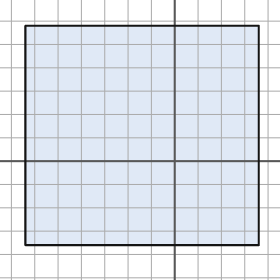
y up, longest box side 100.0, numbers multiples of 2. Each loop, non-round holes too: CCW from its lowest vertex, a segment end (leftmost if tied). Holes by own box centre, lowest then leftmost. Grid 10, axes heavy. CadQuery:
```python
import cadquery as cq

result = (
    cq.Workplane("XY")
    .moveTo(-64.0, -36.0)
    .lineTo(36.0, -36.0)
    .lineTo(36.0, 58.0)
    .lineTo(-64.0, 58.0)
    .close()
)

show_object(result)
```